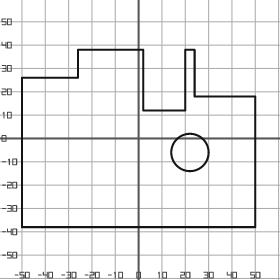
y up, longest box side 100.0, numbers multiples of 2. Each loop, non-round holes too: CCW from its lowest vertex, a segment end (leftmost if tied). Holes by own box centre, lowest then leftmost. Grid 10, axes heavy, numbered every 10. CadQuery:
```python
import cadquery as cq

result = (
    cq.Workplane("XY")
    .moveTo(-50.0, -38.0)
    .lineTo(50.0, -38.0)
    .lineTo(50.0, 18.0)
    .lineTo(24.0, 18.0)
    .lineTo(24.0, 38.0)
    .lineTo(20.0, 38.0)
    .lineTo(20.0, 12.0)
    .lineTo(2.0, 12.0)
    .lineTo(2.0, 38.0)
    .lineTo(-26.0, 38.0)
    .lineTo(-26.0, 26.0)
    .lineTo(-50.0, 26.0)
    .close()
    .moveTo(22.0, -6.0)
    .circle(8.0)
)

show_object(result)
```